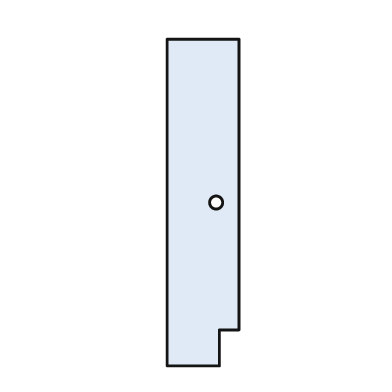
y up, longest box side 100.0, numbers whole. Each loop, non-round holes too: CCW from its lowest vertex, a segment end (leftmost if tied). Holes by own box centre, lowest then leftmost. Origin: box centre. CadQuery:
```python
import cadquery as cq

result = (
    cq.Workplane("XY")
    .moveTo(-11.0, -50.0)
    .lineTo(5.0, -50.0)
    .lineTo(5.0, -39.0)
    .lineTo(11.0, -39.0)
    .lineTo(11.0, 50.0)
    .lineTo(-11.0, 50.0)
    .close()
    .moveTo(4.0, 0.0)
    .circle(2.0)
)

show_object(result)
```